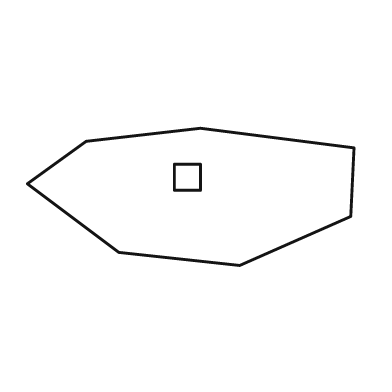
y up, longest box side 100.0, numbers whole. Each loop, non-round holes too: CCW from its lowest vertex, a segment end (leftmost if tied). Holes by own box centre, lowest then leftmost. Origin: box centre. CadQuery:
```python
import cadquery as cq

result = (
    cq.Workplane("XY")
    .moveTo(15.0, -21.0)
    .lineTo(49.0, -6.0)
    .lineTo(50.0, 15.0)
    .lineTo(3.0, 21.0)
    .lineTo(-32.0, 17.0)
    .lineTo(-50.0, 4.0)
    .lineTo(-22.0, -17.0)
    .close()
    .moveTo(-5.0, 2.0)
    .lineTo(3.0, 2.0)
    .lineTo(3.0, 10.0)
    .lineTo(-5.0, 10.0)
    .close()
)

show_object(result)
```